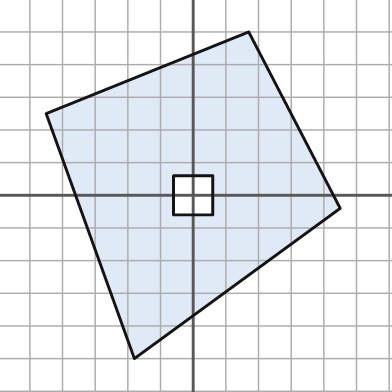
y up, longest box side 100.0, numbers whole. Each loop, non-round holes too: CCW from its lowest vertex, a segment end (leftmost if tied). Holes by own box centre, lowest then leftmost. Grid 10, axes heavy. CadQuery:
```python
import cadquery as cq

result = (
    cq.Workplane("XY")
    .moveTo(-18.0, -50.0)
    .lineTo(45.0, -4.0)
    .lineTo(17.0, 50.0)
    .lineTo(-45.0, 25.0)
    .close()
    .moveTo(-6.0, -6.0)
    .lineTo(6.0, -6.0)
    .lineTo(6.0, 6.0)
    .lineTo(-6.0, 6.0)
    .close()
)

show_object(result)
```